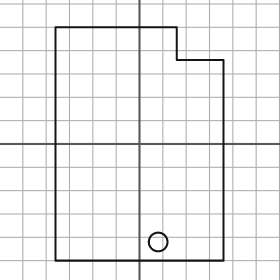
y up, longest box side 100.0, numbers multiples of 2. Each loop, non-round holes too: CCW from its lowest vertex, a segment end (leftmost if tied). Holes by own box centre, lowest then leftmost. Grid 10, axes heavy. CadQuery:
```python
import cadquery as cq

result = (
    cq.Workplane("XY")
    .moveTo(-36.0, -50.0)
    .lineTo(36.0, -50.0)
    .lineTo(36.0, 36.0)
    .lineTo(16.0, 36.0)
    .lineTo(16.0, 50.0)
    .lineTo(-36.0, 50.0)
    .close()
    .moveTo(8.0, -42.0)
    .circle(4.0)
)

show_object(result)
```